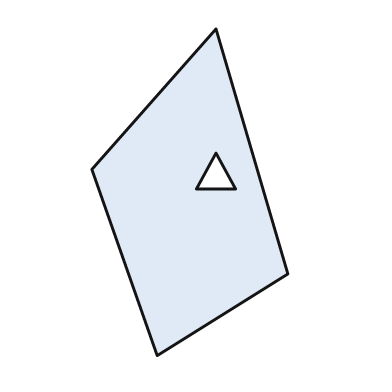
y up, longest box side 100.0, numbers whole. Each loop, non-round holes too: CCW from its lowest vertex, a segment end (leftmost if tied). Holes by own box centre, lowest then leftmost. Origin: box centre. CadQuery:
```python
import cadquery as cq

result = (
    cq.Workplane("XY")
    .moveTo(-10.0, -50.0)
    .lineTo(30.0, -25.0)
    .lineTo(8.0, 50.0)
    .lineTo(-30.0, 7.0)
    .close()
    .moveTo(2.0, 1.0)
    .lineTo(14.0, 1.0)
    .lineTo(8.0, 12.0)
    .close()
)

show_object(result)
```